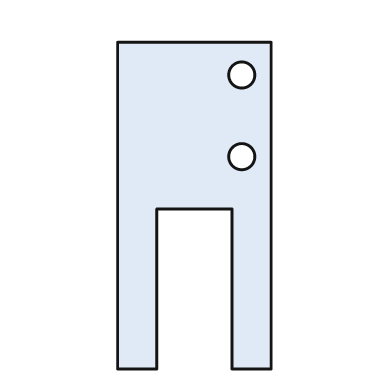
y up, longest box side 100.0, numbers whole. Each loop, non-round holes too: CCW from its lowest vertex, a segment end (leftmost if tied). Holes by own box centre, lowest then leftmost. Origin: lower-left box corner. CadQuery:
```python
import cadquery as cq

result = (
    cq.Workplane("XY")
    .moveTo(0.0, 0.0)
    .lineTo(12.0, 0.0)
    .lineTo(12.0, 49.0)
    .lineTo(35.0, 49.0)
    .lineTo(35.0, 0.0)
    .lineTo(47.0, 0.0)
    .lineTo(47.0, 100.0)
    .lineTo(0.0, 100.0)
    .close()
    .moveTo(38.0, 65.0)
    .circle(4.0)
    .moveTo(38.0, 90.0)
    .circle(4.0)
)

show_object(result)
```